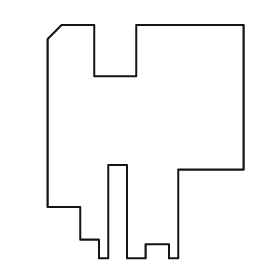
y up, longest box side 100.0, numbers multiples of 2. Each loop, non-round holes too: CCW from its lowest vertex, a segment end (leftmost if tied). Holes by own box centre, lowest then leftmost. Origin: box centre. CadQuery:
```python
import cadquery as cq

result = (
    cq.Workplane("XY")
    .moveTo(-20.0, -50.0)
    .lineTo(-16.0, -50.0)
    .lineTo(-16.0, -10.0)
    .lineTo(-8.0, -10.0)
    .lineTo(-8.0, -50.0)
    .lineTo(0.0, -50.0)
    .lineTo(0.0, -44.0)
    .lineTo(10.0, -44.0)
    .lineTo(10.0, -50.0)
    .lineTo(14.0, -50.0)
    .lineTo(14.0, -12.0)
    .lineTo(42.0, -12.0)
    .lineTo(42.0, 50.0)
    .lineTo(-4.0, 50.0)
    .lineTo(-4.0, 28.0)
    .lineTo(-22.0, 28.0)
    .lineTo(-22.0, 50.0)
    .lineTo(-36.0, 50.0)
    .lineTo(-42.0, 44.0)
    .lineTo(-42.0, -28.0)
    .lineTo(-28.0, -28.0)
    .lineTo(-28.0, -42.0)
    .lineTo(-20.0, -42.0)
    .close()
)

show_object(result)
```